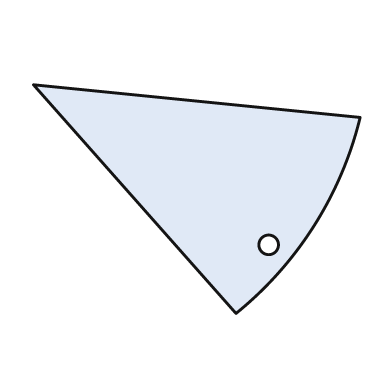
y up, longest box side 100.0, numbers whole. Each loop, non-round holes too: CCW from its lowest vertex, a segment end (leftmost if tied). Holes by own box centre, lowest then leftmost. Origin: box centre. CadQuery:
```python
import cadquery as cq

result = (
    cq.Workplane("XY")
    .moveTo(12.0, -35.0)
    .threePointArc((36.0, -8.0), (50.0, 25.0))
    .lineTo(-50.0, 35.0)
    .close()
    .moveTo(22.0, -14.0)
    .circle(3.0)
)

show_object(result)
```